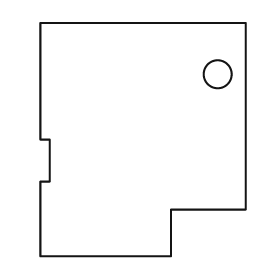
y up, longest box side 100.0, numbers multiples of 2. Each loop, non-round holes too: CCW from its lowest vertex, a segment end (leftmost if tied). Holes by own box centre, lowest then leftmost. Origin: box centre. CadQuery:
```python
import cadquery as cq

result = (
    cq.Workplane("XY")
    .moveTo(-44.0, -50.0)
    .lineTo(12.0, -50.0)
    .lineTo(12.0, -30.0)
    .lineTo(44.0, -30.0)
    .lineTo(44.0, 50.0)
    .lineTo(-44.0, 50.0)
    .lineTo(-44.0, 0.0)
    .lineTo(-40.0, 0.0)
    .lineTo(-40.0, -18.0)
    .lineTo(-44.0, -18.0)
    .close()
    .moveTo(32.0, 28.0)
    .circle(6.0)
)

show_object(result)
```